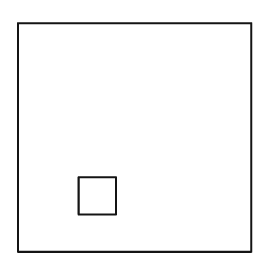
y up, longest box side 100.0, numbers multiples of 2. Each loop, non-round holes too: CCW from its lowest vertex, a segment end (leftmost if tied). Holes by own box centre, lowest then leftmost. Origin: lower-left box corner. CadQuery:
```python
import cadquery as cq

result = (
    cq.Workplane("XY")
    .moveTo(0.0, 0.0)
    .lineTo(100.0, 0.0)
    .lineTo(100.0, 98.0)
    .lineTo(0.0, 98.0)
    .close()
    .moveTo(26.0, 16.0)
    .lineTo(42.0, 16.0)
    .lineTo(42.0, 32.0)
    .lineTo(26.0, 32.0)
    .close()
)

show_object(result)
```